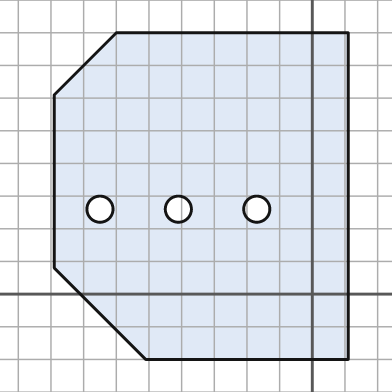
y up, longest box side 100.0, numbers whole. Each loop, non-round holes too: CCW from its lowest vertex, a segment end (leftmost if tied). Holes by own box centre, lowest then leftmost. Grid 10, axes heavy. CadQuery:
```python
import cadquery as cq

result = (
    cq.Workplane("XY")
    .moveTo(-51.0, -20.0)
    .lineTo(11.0, -20.0)
    .lineTo(11.0, 80.0)
    .lineTo(-60.0, 80.0)
    .lineTo(-79.0, 61.0)
    .lineTo(-79.0, 8.0)
    .close()
    .moveTo(-65.0, 26.0)
    .circle(4.0)
    .moveTo(-41.0, 26.0)
    .circle(4.0)
    .moveTo(-17.0, 26.0)
    .circle(4.0)
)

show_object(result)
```